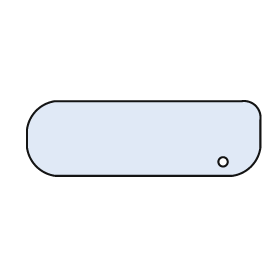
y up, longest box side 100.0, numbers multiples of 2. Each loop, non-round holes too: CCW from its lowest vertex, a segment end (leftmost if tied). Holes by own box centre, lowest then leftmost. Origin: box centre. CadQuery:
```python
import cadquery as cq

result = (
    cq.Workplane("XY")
    .moveTo(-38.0, -16.0)
    .lineTo(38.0, -16.0)
    .threePointArc((46.0, -12.0), (50.0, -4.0))
    .lineTo(50.0, 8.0)
    .threePointArc((48.0, 14.0), (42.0, 16.0))
    .lineTo(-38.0, 16.0)
    .threePointArc((-46.0, 12.0), (-50.0, 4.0))
    .lineTo(-50.0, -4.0)
    .threePointArc((-46.0, -12.0), (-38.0, -16.0))
    .close()
    .moveTo(34.0, -10.0)
    .circle(2.0)
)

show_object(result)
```